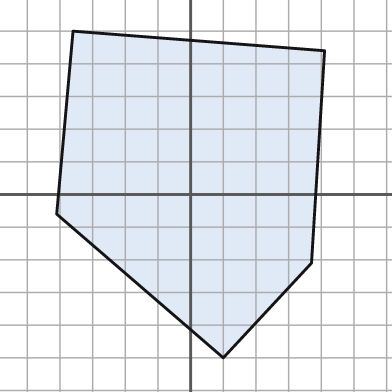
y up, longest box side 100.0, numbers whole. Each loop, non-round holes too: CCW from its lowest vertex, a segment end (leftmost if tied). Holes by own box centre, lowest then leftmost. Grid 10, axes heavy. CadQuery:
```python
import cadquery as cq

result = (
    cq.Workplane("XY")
    .moveTo(10.0, -50.0)
    .lineTo(37.0, -21.0)
    .lineTo(41.0, 44.0)
    .lineTo(-36.0, 50.0)
    .lineTo(-41.0, -6.0)
    .close()
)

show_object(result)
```